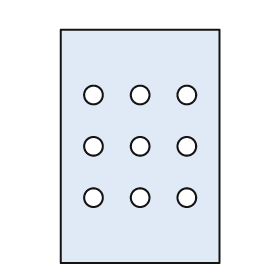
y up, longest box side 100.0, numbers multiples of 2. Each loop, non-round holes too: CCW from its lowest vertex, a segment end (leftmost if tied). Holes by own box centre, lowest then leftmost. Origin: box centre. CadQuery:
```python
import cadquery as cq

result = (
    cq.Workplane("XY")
    .moveTo(-34.0, -50.0)
    .lineTo(34.0, -50.0)
    .lineTo(34.0, 50.0)
    .lineTo(-34.0, 50.0)
    .close()
    .moveTo(-20.0, -22.0)
    .circle(4.0)
    .moveTo(0.0, -22.0)
    .circle(4.0)
    .moveTo(20.0, -22.0)
    .circle(4.0)
    .moveTo(-20.0, 0.0)
    .circle(4.0)
    .moveTo(0.0, 0.0)
    .circle(4.0)
    .moveTo(20.0, 0.0)
    .circle(4.0)
    .moveTo(-20.0, 22.0)
    .circle(4.0)
    .moveTo(0.0, 22.0)
    .circle(4.0)
    .moveTo(20.0, 22.0)
    .circle(4.0)
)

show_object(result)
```